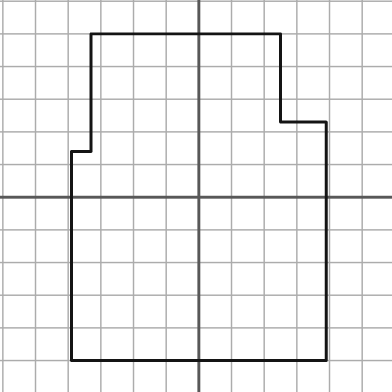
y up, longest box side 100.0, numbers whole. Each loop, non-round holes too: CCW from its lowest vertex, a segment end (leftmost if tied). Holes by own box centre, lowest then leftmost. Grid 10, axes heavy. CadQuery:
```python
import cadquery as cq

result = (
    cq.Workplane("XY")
    .moveTo(-39.0, -50.0)
    .lineTo(39.0, -50.0)
    .lineTo(39.0, 23.0)
    .lineTo(25.0, 23.0)
    .lineTo(25.0, 50.0)
    .lineTo(-33.0, 50.0)
    .lineTo(-33.0, 14.0)
    .lineTo(-39.0, 14.0)
    .close()
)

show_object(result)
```